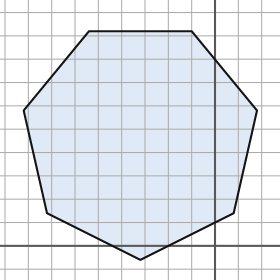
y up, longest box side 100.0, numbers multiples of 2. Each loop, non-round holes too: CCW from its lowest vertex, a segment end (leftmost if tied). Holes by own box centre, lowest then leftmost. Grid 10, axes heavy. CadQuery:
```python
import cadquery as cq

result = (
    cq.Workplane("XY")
    .moveTo(-32.0, -6.0)
    .lineTo(8.0, 14.0)
    .lineTo(18.0, 58.0)
    .lineTo(-10.0, 92.0)
    .lineTo(-54.0, 92.0)
    .lineTo(-82.0, 58.0)
    .lineTo(-72.0, 14.0)
    .close()
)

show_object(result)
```